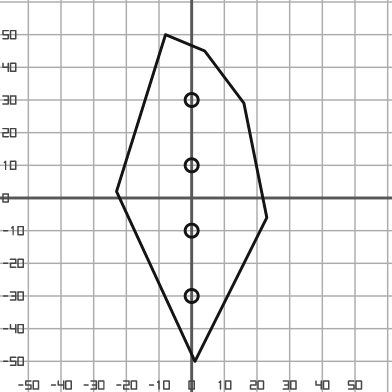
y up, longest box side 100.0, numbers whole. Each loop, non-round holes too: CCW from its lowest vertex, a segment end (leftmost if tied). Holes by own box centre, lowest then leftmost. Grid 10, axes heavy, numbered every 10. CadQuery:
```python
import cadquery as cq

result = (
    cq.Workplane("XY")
    .moveTo(1.0, -50.0)
    .lineTo(23.0, -6.0)
    .lineTo(16.0, 29.0)
    .lineTo(4.0, 45.0)
    .lineTo(-8.0, 50.0)
    .lineTo(-23.0, 2.0)
    .close()
    .moveTo(0.0, -30.0)
    .circle(2.0)
    .moveTo(0.0, -10.0)
    .circle(2.0)
    .moveTo(0.0, 10.0)
    .circle(2.0)
    .moveTo(0.0, 30.0)
    .circle(2.0)
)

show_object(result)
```